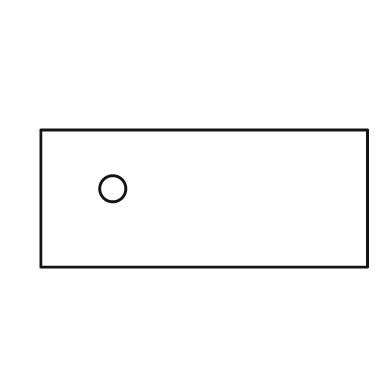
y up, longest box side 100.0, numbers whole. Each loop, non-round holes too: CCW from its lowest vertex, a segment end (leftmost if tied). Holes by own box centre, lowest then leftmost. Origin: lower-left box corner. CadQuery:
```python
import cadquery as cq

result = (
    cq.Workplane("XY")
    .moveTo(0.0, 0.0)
    .lineTo(100.0, 0.0)
    .lineTo(100.0, 42.0)
    .lineTo(0.0, 42.0)
    .close()
    .moveTo(22.0, 24.0)
    .circle(4.0)
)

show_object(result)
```